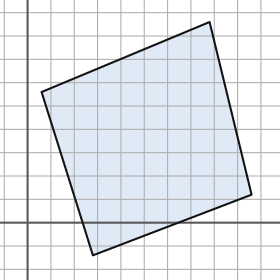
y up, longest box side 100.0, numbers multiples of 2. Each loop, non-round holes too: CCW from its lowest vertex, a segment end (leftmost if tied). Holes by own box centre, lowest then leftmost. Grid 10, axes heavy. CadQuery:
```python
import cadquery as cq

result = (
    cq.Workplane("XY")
    .moveTo(28.0, -14.0)
    .lineTo(96.0, 12.0)
    .lineTo(78.0, 86.0)
    .lineTo(6.0, 56.0)
    .close()
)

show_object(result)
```